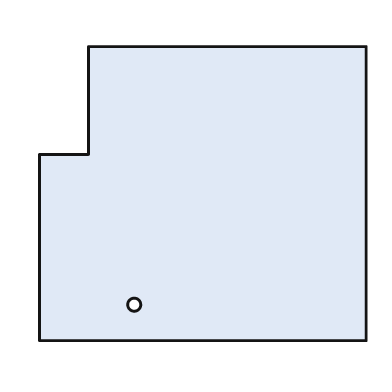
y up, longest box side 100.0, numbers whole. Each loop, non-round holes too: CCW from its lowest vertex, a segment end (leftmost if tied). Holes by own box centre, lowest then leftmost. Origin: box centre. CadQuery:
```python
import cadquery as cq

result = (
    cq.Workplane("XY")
    .moveTo(-50.0, -45.0)
    .lineTo(50.0, -45.0)
    .lineTo(50.0, 45.0)
    .lineTo(-35.0, 45.0)
    .lineTo(-35.0, 12.0)
    .lineTo(-50.0, 12.0)
    .close()
    .moveTo(-21.0, -34.0)
    .circle(2.0)
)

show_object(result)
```